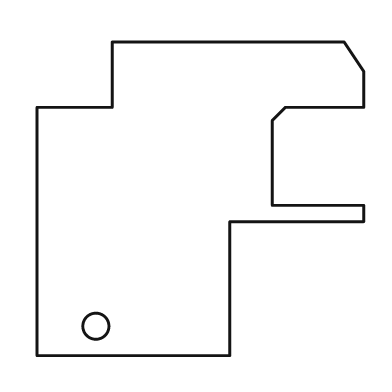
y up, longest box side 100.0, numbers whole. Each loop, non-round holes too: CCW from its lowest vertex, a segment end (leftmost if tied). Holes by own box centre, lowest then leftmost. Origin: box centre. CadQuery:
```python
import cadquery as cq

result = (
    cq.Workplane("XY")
    .moveTo(-50.0, -48.0)
    .lineTo(9.0, -48.0)
    .lineTo(9.0, -7.0)
    .lineTo(50.0, -7.0)
    .lineTo(50.0, -2.0)
    .lineTo(22.0, -2.0)
    .lineTo(22.0, 24.0)
    .lineTo(26.0, 28.0)
    .lineTo(50.0, 28.0)
    .lineTo(50.0, 39.0)
    .lineTo(44.0, 48.0)
    .lineTo(-27.0, 48.0)
    .lineTo(-27.0, 28.0)
    .lineTo(-50.0, 28.0)
    .close()
    .moveTo(-32.0, -39.0)
    .circle(4.0)
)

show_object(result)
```